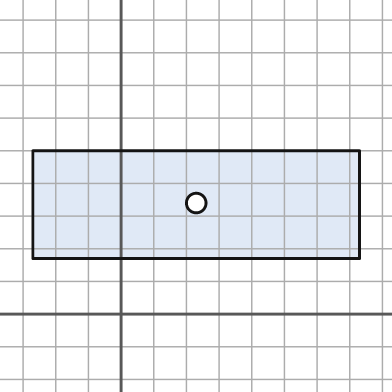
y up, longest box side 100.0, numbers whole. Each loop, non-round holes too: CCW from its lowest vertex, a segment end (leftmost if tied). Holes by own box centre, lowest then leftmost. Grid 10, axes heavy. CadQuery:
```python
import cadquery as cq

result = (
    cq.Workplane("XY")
    .moveTo(-27.0, 17.0)
    .lineTo(73.0, 17.0)
    .lineTo(73.0, 50.0)
    .lineTo(-27.0, 50.0)
    .close()
    .moveTo(23.0, 34.0)
    .circle(3.0)
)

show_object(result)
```